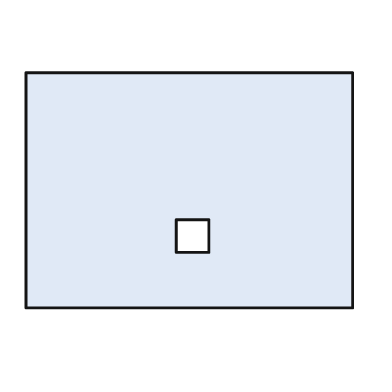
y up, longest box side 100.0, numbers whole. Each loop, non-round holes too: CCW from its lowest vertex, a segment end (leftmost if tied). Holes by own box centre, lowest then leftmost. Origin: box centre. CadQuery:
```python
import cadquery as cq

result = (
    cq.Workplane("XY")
    .moveTo(-50.0, -36.0)
    .lineTo(50.0, -36.0)
    .lineTo(50.0, 36.0)
    .lineTo(-50.0, 36.0)
    .close()
    .moveTo(-4.0, -19.0)
    .lineTo(6.0, -19.0)
    .lineTo(6.0, -9.0)
    .lineTo(-4.0, -9.0)
    .close()
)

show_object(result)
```